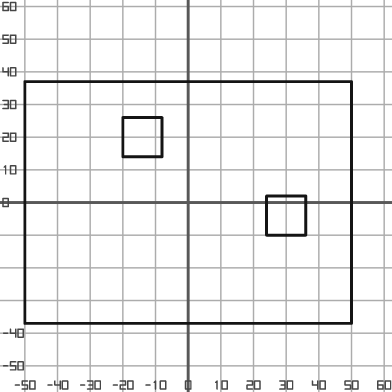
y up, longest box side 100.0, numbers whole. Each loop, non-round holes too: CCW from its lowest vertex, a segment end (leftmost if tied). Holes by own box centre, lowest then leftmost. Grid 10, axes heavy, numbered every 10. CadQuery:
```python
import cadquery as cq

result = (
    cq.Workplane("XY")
    .moveTo(-50.0, -37.0)
    .lineTo(50.0, -37.0)
    .lineTo(50.0, 37.0)
    .lineTo(-50.0, 37.0)
    .close()
    .moveTo(24.0, -10.0)
    .lineTo(36.0, -10.0)
    .lineTo(36.0, 2.0)
    .lineTo(24.0, 2.0)
    .close()
    .moveTo(-20.0, 14.0)
    .lineTo(-8.0, 14.0)
    .lineTo(-8.0, 26.0)
    .lineTo(-20.0, 26.0)
    .close()
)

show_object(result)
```